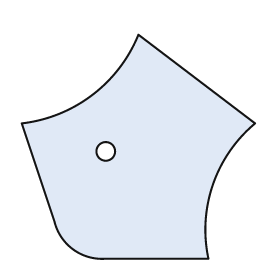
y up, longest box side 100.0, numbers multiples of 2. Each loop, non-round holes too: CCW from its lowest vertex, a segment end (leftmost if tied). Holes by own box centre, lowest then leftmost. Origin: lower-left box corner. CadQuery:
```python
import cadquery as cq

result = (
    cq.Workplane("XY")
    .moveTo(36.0, 0.0)
    .lineTo(80.0, 0.0)
    .threePointArc((82.0, 32.0), (100.0, 58.0))
    .lineTo(50.0, 96.0)
    .threePointArc((30.0, 70.0), (0.0, 58.0))
    .lineTo(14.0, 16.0)
    .threePointArc((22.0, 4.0), (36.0, 0.0))
    .close()
    .moveTo(36.0, 46.0)
    .circle(4.0)
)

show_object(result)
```